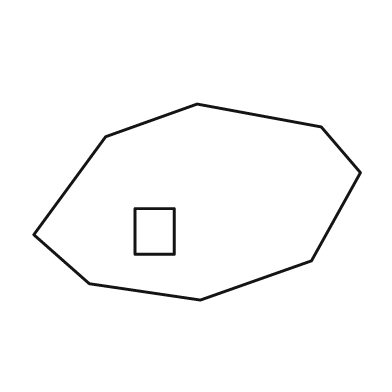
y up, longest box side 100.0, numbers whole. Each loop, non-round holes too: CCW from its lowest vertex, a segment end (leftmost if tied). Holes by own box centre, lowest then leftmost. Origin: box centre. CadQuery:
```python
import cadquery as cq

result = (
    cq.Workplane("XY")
    .moveTo(1.0, -30.0)
    .lineTo(35.0, -18.0)
    .lineTo(50.0, 9.0)
    .lineTo(38.0, 23.0)
    .lineTo(0.0, 30.0)
    .lineTo(-28.0, 20.0)
    .lineTo(-50.0, -10.0)
    .lineTo(-33.0, -25.0)
    .close()
    .moveTo(-19.0, -16.0)
    .lineTo(-7.0, -16.0)
    .lineTo(-7.0, -2.0)
    .lineTo(-19.0, -2.0)
    .close()
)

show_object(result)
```